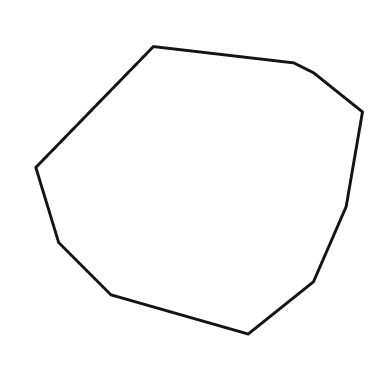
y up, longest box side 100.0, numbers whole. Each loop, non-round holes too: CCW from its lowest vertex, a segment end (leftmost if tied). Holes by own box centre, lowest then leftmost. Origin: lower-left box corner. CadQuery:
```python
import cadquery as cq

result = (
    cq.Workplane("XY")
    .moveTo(65.0, 0.0)
    .lineTo(85.0, 16.0)
    .lineTo(95.0, 39.0)
    .lineTo(100.0, 68.0)
    .lineTo(85.0, 80.0)
    .lineTo(79.0, 83.0)
    .lineTo(36.0, 88.0)
    .lineTo(0.0, 51.0)
    .lineTo(7.0, 28.0)
    .lineTo(23.0, 12.0)
    .close()
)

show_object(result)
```